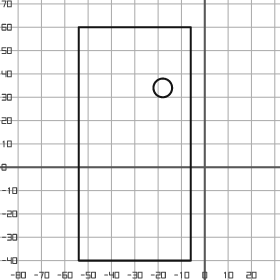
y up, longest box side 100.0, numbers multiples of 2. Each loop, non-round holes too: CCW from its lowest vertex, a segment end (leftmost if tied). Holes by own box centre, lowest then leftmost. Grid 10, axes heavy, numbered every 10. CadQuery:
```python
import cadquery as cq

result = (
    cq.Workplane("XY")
    .moveTo(-54.0, -40.0)
    .lineTo(-6.0, -40.0)
    .lineTo(-6.0, 60.0)
    .lineTo(-54.0, 60.0)
    .close()
    .moveTo(-18.0, 34.0)
    .circle(4.0)
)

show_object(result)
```